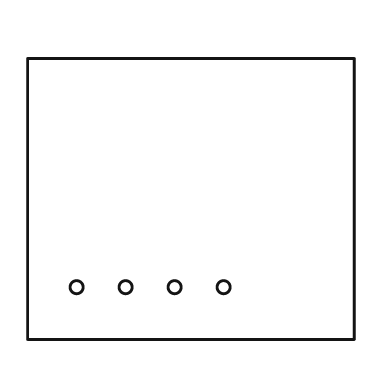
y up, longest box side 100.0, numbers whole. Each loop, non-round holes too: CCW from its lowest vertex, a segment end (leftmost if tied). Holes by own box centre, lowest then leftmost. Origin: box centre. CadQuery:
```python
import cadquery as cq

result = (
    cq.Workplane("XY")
    .moveTo(-50.0, -43.0)
    .lineTo(50.0, -43.0)
    .lineTo(50.0, 43.0)
    .lineTo(-50.0, 43.0)
    .close()
    .moveTo(-35.0, -27.0)
    .circle(2.0)
    .moveTo(-20.0, -27.0)
    .circle(2.0)
    .moveTo(-5.0, -27.0)
    .circle(2.0)
    .moveTo(10.0, -27.0)
    .circle(2.0)
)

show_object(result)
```